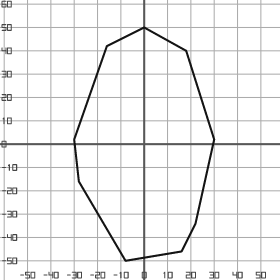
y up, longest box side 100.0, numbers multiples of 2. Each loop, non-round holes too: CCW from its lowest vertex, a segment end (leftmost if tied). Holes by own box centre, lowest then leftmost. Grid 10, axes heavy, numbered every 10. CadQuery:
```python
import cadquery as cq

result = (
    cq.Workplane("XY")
    .moveTo(-8.0, -50.0)
    .lineTo(16.0, -46.0)
    .lineTo(22.0, -34.0)
    .lineTo(30.0, 2.0)
    .lineTo(18.0, 40.0)
    .lineTo(0.0, 50.0)
    .lineTo(-16.0, 42.0)
    .lineTo(-30.0, 2.0)
    .lineTo(-28.0, -16.0)
    .close()
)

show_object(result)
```